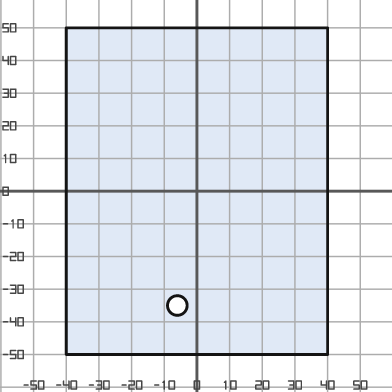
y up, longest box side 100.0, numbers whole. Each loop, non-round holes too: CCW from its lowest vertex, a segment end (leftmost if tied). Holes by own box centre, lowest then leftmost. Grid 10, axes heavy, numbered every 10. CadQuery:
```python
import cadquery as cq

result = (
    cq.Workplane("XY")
    .moveTo(-40.0, -50.0)
    .lineTo(40.0, -50.0)
    .lineTo(40.0, 50.0)
    .lineTo(-40.0, 50.0)
    .close()
    .moveTo(-6.0, -35.0)
    .circle(3.0)
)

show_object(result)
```